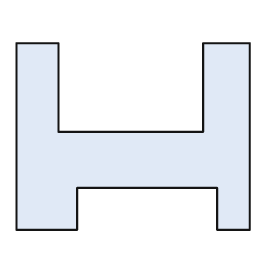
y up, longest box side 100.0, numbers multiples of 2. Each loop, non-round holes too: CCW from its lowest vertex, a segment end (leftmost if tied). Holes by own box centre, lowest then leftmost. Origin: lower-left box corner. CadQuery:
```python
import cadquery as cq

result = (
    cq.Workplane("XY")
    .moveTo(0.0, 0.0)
    .lineTo(26.0, 0.0)
    .lineTo(26.0, 18.0)
    .lineTo(86.0, 18.0)
    .lineTo(86.0, 0.0)
    .lineTo(100.0, 0.0)
    .lineTo(100.0, 80.0)
    .lineTo(80.0, 80.0)
    .lineTo(80.0, 42.0)
    .lineTo(18.0, 42.0)
    .lineTo(18.0, 80.0)
    .lineTo(0.0, 80.0)
    .close()
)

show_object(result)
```